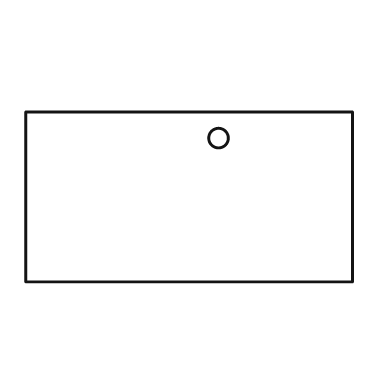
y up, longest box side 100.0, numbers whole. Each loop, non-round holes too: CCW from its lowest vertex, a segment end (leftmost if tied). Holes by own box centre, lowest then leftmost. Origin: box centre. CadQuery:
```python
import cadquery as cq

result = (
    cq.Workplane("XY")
    .moveTo(-50.0, -26.0)
    .lineTo(50.0, -26.0)
    .lineTo(50.0, 26.0)
    .lineTo(-50.0, 26.0)
    .close()
    .moveTo(9.0, 18.0)
    .circle(3.0)
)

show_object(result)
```